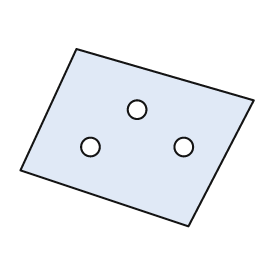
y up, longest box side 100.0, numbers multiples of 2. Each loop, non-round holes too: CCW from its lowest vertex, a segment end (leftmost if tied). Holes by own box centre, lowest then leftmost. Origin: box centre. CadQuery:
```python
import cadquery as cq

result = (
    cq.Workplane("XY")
    .moveTo(22.0, -38.0)
    .lineTo(50.0, 16.0)
    .lineTo(-26.0, 38.0)
    .lineTo(-50.0, -14.0)
    .close()
    .moveTo(-20.0, -4.0)
    .circle(4.0)
    .moveTo(20.0, -4.0)
    .circle(4.0)
    .moveTo(0.0, 12.0)
    .circle(4.0)
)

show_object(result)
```